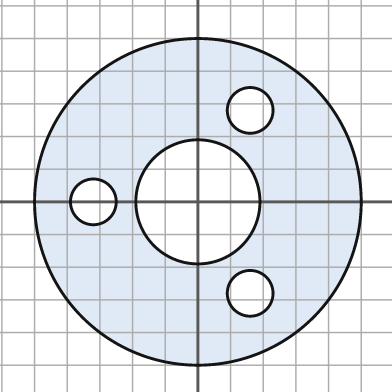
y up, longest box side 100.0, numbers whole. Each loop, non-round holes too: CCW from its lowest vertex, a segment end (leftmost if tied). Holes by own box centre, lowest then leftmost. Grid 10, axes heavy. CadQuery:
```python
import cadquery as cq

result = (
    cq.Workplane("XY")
    .moveTo(0.0, 0.0)
    .circle(50.0)
    .moveTo(16.0, -28.0)
    .circle(7.0)
    .moveTo(-32.0, 0.0)
    .circle(7.0)
    .moveTo(0.0, 0.0)
    .circle(19.0)
    .moveTo(16.0, 28.0)
    .circle(7.0)
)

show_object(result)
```